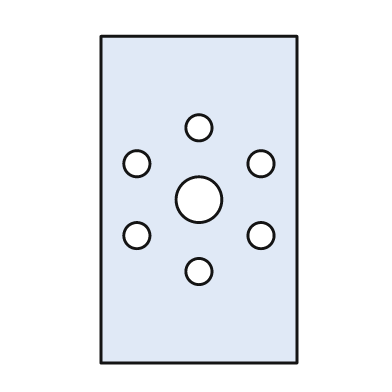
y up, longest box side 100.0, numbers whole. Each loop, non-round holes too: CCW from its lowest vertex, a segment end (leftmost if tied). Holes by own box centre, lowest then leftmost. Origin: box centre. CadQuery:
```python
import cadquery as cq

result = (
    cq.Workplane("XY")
    .moveTo(-30.0, -50.0)
    .lineTo(30.0, -50.0)
    .lineTo(30.0, 50.0)
    .lineTo(-30.0, 50.0)
    .close()
    .moveTo(0.0, -22.0)
    .circle(4.0)
    .moveTo(-19.0, -11.0)
    .circle(4.0)
    .moveTo(19.0, -11.0)
    .circle(4.0)
    .moveTo(0.0, 0.0)
    .circle(7.0)
    .moveTo(-19.0, 11.0)
    .circle(4.0)
    .moveTo(19.0, 11.0)
    .circle(4.0)
    .moveTo(0.0, 22.0)
    .circle(4.0)
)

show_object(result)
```